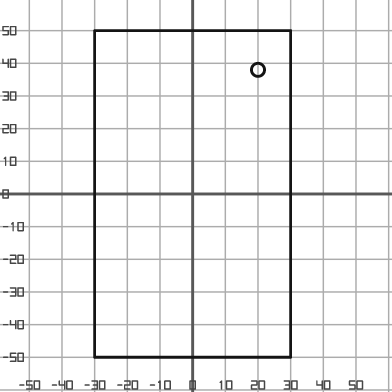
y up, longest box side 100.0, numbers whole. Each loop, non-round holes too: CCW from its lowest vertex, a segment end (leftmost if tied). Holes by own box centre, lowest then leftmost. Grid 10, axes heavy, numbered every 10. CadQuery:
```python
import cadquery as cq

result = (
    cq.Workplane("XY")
    .moveTo(-30.0, -50.0)
    .lineTo(30.0, -50.0)
    .lineTo(30.0, 50.0)
    .lineTo(-30.0, 50.0)
    .close()
    .moveTo(20.0, 38.0)
    .circle(2.0)
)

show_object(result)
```